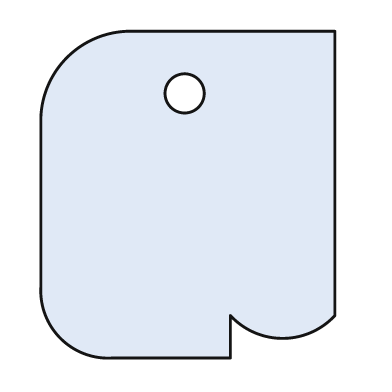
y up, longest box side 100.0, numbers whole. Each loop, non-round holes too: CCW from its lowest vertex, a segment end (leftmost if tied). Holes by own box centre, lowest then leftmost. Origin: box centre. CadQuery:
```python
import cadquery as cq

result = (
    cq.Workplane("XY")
    .moveTo(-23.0, -50.0)
    .lineTo(13.0, -50.0)
    .lineTo(13.0, -37.0)
    .threePointArc((29.0, -44.0), (45.0, -37.0))
    .lineTo(45.0, 50.0)
    .lineTo(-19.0, 50.0)
    .threePointArc((-37.0, 42.0), (-45.0, 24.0))
    .lineTo(-45.0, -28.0)
    .threePointArc((-39.0, -44.0), (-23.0, -50.0))
    .close()
    .moveTo(-1.0, 31.0)
    .circle(6.0)
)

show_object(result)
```